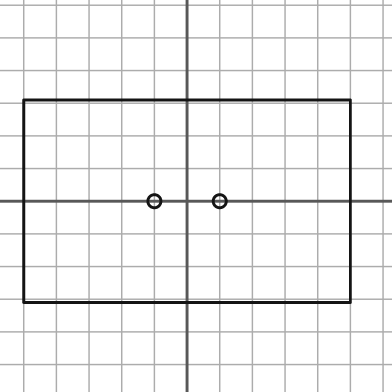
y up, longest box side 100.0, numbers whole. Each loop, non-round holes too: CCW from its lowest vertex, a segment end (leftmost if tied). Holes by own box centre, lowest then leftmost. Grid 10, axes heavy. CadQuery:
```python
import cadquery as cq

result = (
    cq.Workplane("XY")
    .moveTo(-50.0, -31.0)
    .lineTo(50.0, -31.0)
    .lineTo(50.0, 31.0)
    .lineTo(-50.0, 31.0)
    .close()
    .moveTo(-10.0, 0.0)
    .circle(2.0)
    .moveTo(10.0, 0.0)
    .circle(2.0)
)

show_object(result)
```